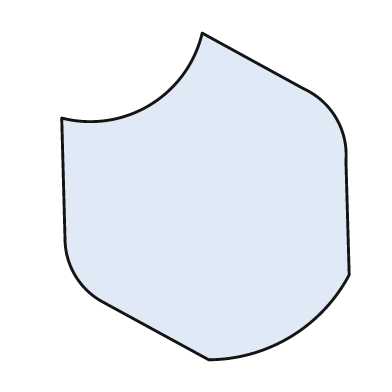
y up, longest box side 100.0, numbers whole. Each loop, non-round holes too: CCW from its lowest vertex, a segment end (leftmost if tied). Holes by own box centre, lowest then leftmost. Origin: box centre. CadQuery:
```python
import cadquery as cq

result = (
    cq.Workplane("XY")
    .moveTo(1.0, -50.0)
    .threePointArc((26.0, -43.0), (44.0, -24.0))
    .lineTo(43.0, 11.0)
    .threePointArc((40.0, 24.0), (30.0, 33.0))
    .lineTo(-1.0, 50.0)
    .threePointArc((-17.0, 28.0), (-44.0, 24.0))
    .lineTo(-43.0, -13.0)
    .threePointArc((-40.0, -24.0), (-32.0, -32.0))
    .close()
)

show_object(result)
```